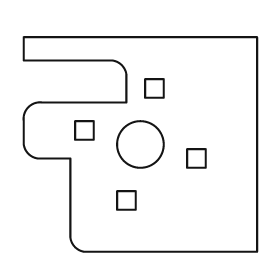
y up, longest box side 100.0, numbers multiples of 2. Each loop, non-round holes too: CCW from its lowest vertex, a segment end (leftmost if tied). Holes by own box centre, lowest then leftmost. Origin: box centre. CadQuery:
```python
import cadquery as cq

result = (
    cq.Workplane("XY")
    .moveTo(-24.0, -46.0)
    .lineTo(50.0, -46.0)
    .lineTo(50.0, 46.0)
    .lineTo(-50.0, 46.0)
    .lineTo(-50.0, 36.0)
    .lineTo(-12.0, 36.0)
    .threePointArc((-8.0, 34.0), (-6.0, 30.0))
    .lineTo(-6.0, 18.0)
    .lineTo(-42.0, 18.0)
    .threePointArc((-48.0, 16.0), (-50.0, 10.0))
    .lineTo(-50.0, 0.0)
    .threePointArc((-48.0, -4.0), (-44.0, -6.0))
    .lineTo(-30.0, -6.0)
    .lineTo(-30.0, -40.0)
    .threePointArc((-28.0, -44.0), (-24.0, -46.0))
    .close()
    .moveTo(-10.0, -28.0)
    .lineTo(-2.0, -28.0)
    .lineTo(-2.0, -20.0)
    .lineTo(-10.0, -20.0)
    .close()
    .moveTo(20.0, -10.0)
    .lineTo(28.0, -10.0)
    .lineTo(28.0, -2.0)
    .lineTo(20.0, -2.0)
    .close()
    .moveTo(0.0, 0.0)
    .circle(10.0)
    .moveTo(-28.0, 2.0)
    .lineTo(-20.0, 2.0)
    .lineTo(-20.0, 10.0)
    .lineTo(-28.0, 10.0)
    .close()
    .moveTo(2.0, 20.0)
    .lineTo(10.0, 20.0)
    .lineTo(10.0, 28.0)
    .lineTo(2.0, 28.0)
    .close()
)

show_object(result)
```